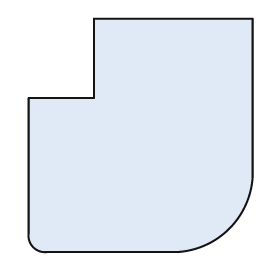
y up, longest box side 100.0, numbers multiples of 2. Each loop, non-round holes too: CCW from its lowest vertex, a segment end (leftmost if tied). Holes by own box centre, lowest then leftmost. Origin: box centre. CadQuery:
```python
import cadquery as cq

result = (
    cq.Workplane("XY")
    .moveTo(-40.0, -50.0)
    .lineTo(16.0, -50.0)
    .threePointArc((38.0, -40.0), (48.0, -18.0))
    .lineTo(48.0, 50.0)
    .lineTo(-20.0, 50.0)
    .lineTo(-20.0, 16.0)
    .lineTo(-48.0, 16.0)
    .lineTo(-48.0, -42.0)
    .threePointArc((-46.0, -48.0), (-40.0, -50.0))
    .close()
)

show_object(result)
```